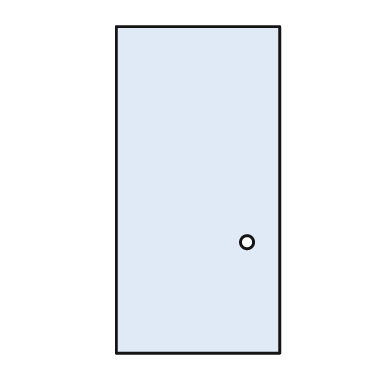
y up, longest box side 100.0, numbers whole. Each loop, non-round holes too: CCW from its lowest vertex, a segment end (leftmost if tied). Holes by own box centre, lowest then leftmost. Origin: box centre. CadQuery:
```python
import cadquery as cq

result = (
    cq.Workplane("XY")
    .moveTo(-25.0, -50.0)
    .lineTo(25.0, -50.0)
    .lineTo(25.0, 50.0)
    .lineTo(-25.0, 50.0)
    .close()
    .moveTo(15.0, -16.0)
    .circle(2.0)
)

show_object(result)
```